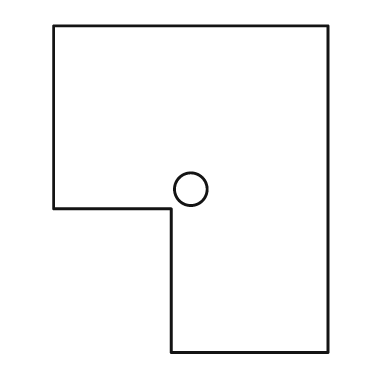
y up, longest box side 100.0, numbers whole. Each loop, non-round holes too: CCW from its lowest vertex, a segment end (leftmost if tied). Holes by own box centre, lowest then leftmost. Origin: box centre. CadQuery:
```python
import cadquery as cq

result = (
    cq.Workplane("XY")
    .moveTo(-6.0, -50.0)
    .lineTo(42.0, -50.0)
    .lineTo(42.0, 50.0)
    .lineTo(-42.0, 50.0)
    .lineTo(-42.0, -6.0)
    .lineTo(-6.0, -6.0)
    .close()
    .moveTo(0.0, 0.0)
    .circle(5.0)
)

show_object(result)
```